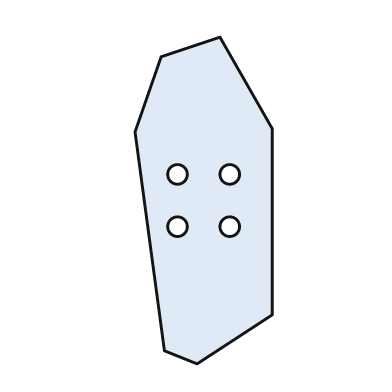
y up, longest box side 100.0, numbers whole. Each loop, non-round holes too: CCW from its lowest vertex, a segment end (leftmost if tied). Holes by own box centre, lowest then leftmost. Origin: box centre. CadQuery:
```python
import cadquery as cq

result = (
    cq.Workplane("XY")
    .moveTo(-2.0, -50.0)
    .lineTo(21.0, -35.0)
    .lineTo(21.0, 22.0)
    .lineTo(5.0, 50.0)
    .lineTo(-13.0, 44.0)
    .lineTo(-21.0, 21.0)
    .lineTo(-12.0, -46.0)
    .close()
    .moveTo(-8.0, -8.0)
    .circle(3.0)
    .moveTo(8.0, -8.0)
    .circle(3.0)
    .moveTo(-8.0, 8.0)
    .circle(3.0)
    .moveTo(8.0, 8.0)
    .circle(3.0)
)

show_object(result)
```